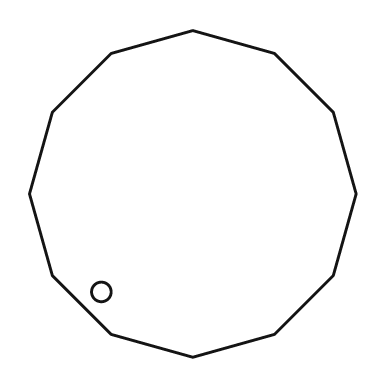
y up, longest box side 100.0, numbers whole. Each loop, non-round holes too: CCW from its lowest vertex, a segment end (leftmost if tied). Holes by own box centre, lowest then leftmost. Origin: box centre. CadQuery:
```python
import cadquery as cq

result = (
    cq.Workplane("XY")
    .moveTo(0.0, -50.0)
    .lineTo(25.0, -43.0)
    .lineTo(43.0, -25.0)
    .lineTo(50.0, 0.0)
    .lineTo(43.0, 25.0)
    .lineTo(25.0, 43.0)
    .lineTo(0.0, 50.0)
    .lineTo(-25.0, 43.0)
    .lineTo(-43.0, 25.0)
    .lineTo(-50.0, 0.0)
    .lineTo(-43.0, -25.0)
    .lineTo(-25.0, -43.0)
    .close()
    .moveTo(-28.0, -30.0)
    .circle(3.0)
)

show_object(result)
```